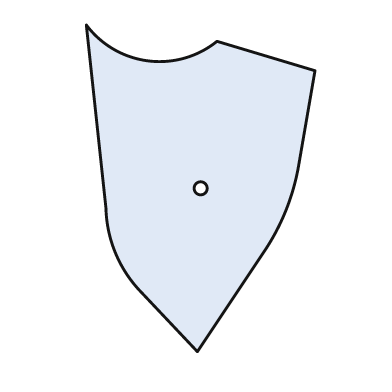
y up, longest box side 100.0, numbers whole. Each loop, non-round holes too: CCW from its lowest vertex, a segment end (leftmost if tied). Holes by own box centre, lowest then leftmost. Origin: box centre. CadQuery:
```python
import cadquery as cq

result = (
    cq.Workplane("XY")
    .moveTo(-1.0, -50.0)
    .lineTo(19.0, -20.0)
    .threePointArc((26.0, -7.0), (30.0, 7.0))
    .lineTo(35.0, 36.0)
    .lineTo(5.0, 45.0)
    .threePointArc((-16.0, 39.0), (-35.0, 50.0))
    .lineTo(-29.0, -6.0)
    .threePointArc((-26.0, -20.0), (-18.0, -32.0))
    .close()
    .moveTo(0.0, 0.0)
    .circle(2.0)
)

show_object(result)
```